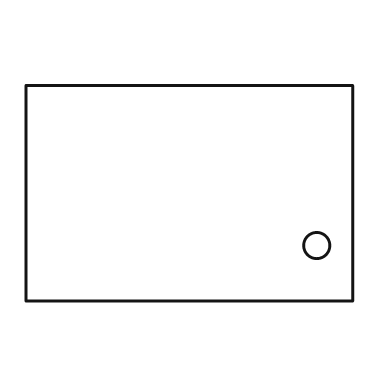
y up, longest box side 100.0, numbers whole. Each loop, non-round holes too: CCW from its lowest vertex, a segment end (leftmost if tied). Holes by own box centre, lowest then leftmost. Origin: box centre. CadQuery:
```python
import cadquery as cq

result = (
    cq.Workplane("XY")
    .moveTo(-50.0, -33.0)
    .lineTo(50.0, -33.0)
    .lineTo(50.0, 33.0)
    .lineTo(-50.0, 33.0)
    .close()
    .moveTo(39.0, -16.0)
    .circle(4.0)
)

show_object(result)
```